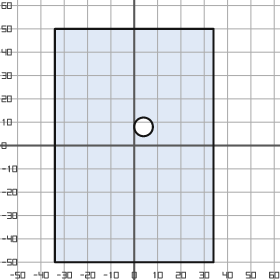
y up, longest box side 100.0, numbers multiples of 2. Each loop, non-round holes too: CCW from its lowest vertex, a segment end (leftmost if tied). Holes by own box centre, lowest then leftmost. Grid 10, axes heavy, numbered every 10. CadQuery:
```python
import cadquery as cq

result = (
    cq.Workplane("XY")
    .moveTo(-34.0, -50.0)
    .lineTo(34.0, -50.0)
    .lineTo(34.0, 50.0)
    .lineTo(-34.0, 50.0)
    .close()
    .moveTo(4.0, 8.0)
    .circle(4.0)
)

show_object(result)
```